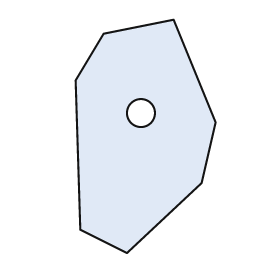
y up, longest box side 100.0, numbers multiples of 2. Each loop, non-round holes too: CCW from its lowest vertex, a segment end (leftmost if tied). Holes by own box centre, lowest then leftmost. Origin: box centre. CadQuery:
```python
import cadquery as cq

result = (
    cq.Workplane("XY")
    .moveTo(-8.0, -50.0)
    .lineTo(24.0, -20.0)
    .lineTo(30.0, 6.0)
    .lineTo(12.0, 50.0)
    .lineTo(-18.0, 44.0)
    .lineTo(-30.0, 24.0)
    .lineTo(-28.0, -40.0)
    .close()
    .moveTo(-2.0, 10.0)
    .circle(6.0)
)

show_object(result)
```